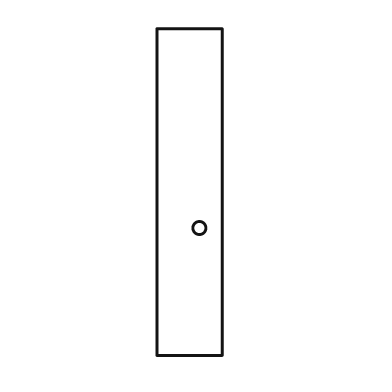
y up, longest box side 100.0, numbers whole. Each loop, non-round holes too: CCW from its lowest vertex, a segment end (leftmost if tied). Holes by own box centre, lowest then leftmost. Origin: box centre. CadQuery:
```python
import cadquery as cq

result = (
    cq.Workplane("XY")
    .moveTo(-10.0, -50.0)
    .lineTo(10.0, -50.0)
    .lineTo(10.0, 50.0)
    .lineTo(-10.0, 50.0)
    .close()
    .moveTo(3.0, -11.0)
    .circle(2.0)
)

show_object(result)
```